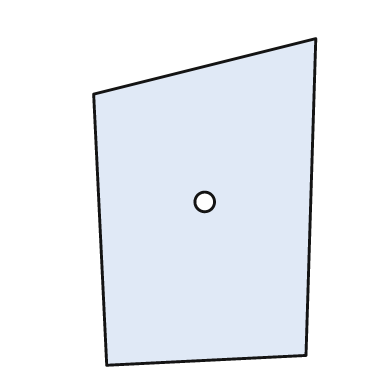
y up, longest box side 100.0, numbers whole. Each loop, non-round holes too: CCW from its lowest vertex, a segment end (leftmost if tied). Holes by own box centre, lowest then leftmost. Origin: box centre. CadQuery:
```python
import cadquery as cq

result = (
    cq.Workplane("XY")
    .moveTo(-30.0, -50.0)
    .lineTo(31.0, -47.0)
    .lineTo(34.0, 50.0)
    .lineTo(-34.0, 33.0)
    .close()
    .moveTo(0.0, 0.0)
    .circle(3.0)
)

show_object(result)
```